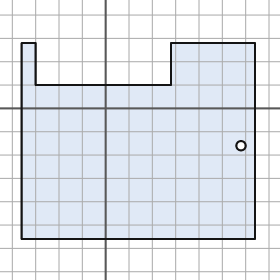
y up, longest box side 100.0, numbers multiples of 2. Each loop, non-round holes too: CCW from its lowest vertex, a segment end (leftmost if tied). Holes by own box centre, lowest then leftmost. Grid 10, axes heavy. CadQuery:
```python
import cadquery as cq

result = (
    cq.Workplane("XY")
    .moveTo(-36.0, -56.0)
    .lineTo(64.0, -56.0)
    .lineTo(64.0, 28.0)
    .lineTo(28.0, 28.0)
    .lineTo(28.0, 10.0)
    .lineTo(-30.0, 10.0)
    .lineTo(-30.0, 28.0)
    .lineTo(-36.0, 28.0)
    .close()
    .moveTo(58.0, -16.0)
    .circle(2.0)
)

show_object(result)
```